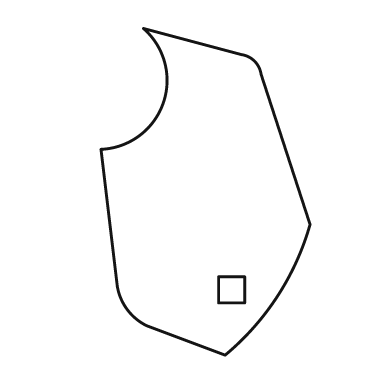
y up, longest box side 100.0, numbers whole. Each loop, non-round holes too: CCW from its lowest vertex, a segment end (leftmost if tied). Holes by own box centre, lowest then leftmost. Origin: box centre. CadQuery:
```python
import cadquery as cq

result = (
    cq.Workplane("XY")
    .moveTo(6.0, -50.0)
    .threePointArc((22.0, -32.0), (32.0, -10.0))
    .lineTo(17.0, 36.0)
    .threePointArc((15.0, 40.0), (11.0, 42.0))
    .lineTo(-19.0, 50.0)
    .threePointArc((-13.0, 27.0), (-32.0, 13.0))
    .lineTo(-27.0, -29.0)
    .threePointArc((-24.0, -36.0), (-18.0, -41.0))
    .close()
    .moveTo(4.0, -34.0)
    .lineTo(12.0, -34.0)
    .lineTo(12.0, -26.0)
    .lineTo(4.0, -26.0)
    .close()
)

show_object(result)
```